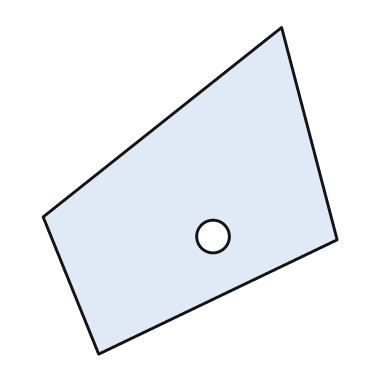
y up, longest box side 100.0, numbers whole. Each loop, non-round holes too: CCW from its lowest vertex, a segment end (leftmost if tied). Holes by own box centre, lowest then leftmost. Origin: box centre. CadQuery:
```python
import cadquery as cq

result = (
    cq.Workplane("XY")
    .moveTo(-28.0, -50.0)
    .lineTo(45.0, -15.0)
    .lineTo(28.0, 50.0)
    .lineTo(-45.0, -8.0)
    .close()
    .moveTo(7.0, -14.0)
    .circle(5.0)
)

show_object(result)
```